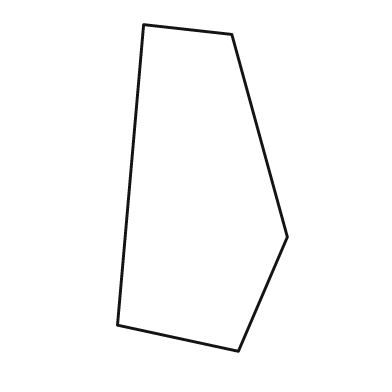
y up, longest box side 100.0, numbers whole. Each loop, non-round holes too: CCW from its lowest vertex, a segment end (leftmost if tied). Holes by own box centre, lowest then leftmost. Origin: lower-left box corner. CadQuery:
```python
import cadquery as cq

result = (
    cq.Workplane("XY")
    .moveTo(37.0, 0.0)
    .lineTo(52.0, 35.0)
    .lineTo(35.0, 97.0)
    .lineTo(8.0, 100.0)
    .lineTo(0.0, 8.0)
    .close()
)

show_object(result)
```